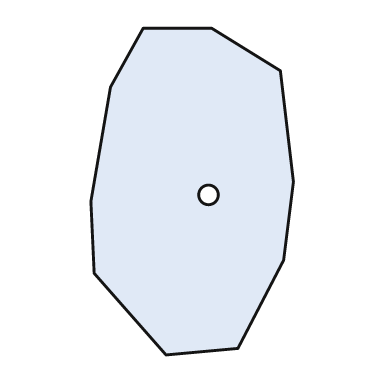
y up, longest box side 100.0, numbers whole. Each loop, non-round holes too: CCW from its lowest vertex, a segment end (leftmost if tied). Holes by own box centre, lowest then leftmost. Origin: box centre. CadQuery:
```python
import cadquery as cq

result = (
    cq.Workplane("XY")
    .moveTo(-8.0, -50.0)
    .lineTo(14.0, -48.0)
    .lineTo(28.0, -21.0)
    .lineTo(31.0, 3.0)
    .lineTo(27.0, 37.0)
    .lineTo(6.0, 50.0)
    .lineTo(-15.0, 50.0)
    .lineTo(-25.0, 32.0)
    .lineTo(-31.0, -3.0)
    .lineTo(-30.0, -25.0)
    .close()
    .moveTo(5.0, -1.0)
    .circle(3.0)
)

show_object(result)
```